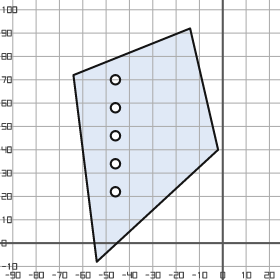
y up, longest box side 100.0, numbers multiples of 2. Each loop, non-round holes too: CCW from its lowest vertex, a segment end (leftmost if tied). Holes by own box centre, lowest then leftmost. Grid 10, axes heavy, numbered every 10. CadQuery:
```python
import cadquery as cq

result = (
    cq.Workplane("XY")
    .moveTo(-54.0, -8.0)
    .lineTo(-2.0, 40.0)
    .lineTo(-14.0, 92.0)
    .lineTo(-64.0, 72.0)
    .close()
    .moveTo(-46.0, 22.0)
    .circle(2.0)
    .moveTo(-46.0, 34.0)
    .circle(2.0)
    .moveTo(-46.0, 46.0)
    .circle(2.0)
    .moveTo(-46.0, 58.0)
    .circle(2.0)
    .moveTo(-46.0, 70.0)
    .circle(2.0)
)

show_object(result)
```